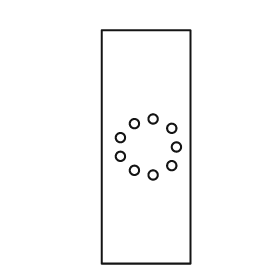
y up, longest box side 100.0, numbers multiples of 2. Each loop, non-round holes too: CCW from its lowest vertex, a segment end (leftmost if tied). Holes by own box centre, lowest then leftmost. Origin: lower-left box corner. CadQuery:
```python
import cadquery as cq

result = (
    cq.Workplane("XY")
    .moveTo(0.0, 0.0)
    .lineTo(38.0, 0.0)
    .lineTo(38.0, 100.0)
    .lineTo(0.0, 100.0)
    .close()
    .moveTo(22.0, 38.0)
    .circle(2.0)
    .moveTo(14.0, 40.0)
    .circle(2.0)
    .moveTo(30.0, 42.0)
    .circle(2.0)
    .moveTo(8.0, 46.0)
    .circle(2.0)
    .moveTo(32.0, 50.0)
    .circle(2.0)
    .moveTo(8.0, 54.0)
    .circle(2.0)
    .moveTo(30.0, 58.0)
    .circle(2.0)
    .moveTo(14.0, 60.0)
    .circle(2.0)
    .moveTo(22.0, 62.0)
    .circle(2.0)
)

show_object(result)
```